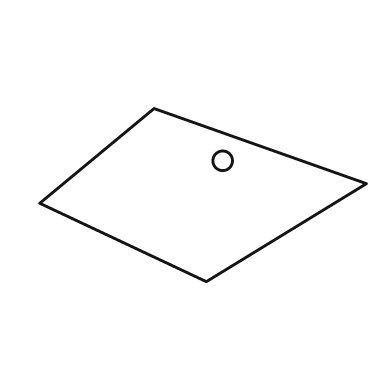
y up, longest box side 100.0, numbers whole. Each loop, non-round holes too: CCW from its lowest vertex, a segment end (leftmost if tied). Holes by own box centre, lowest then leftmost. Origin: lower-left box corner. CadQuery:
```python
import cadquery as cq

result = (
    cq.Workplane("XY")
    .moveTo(51.0, 0.0)
    .lineTo(100.0, 30.0)
    .lineTo(35.0, 53.0)
    .lineTo(0.0, 24.0)
    .close()
    .moveTo(56.0, 37.0)
    .circle(3.0)
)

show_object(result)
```